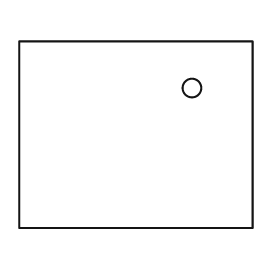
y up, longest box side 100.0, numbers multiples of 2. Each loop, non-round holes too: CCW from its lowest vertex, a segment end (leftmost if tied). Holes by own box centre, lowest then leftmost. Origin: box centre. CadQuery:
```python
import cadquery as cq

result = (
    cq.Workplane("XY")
    .moveTo(-50.0, -40.0)
    .lineTo(50.0, -40.0)
    .lineTo(50.0, 40.0)
    .lineTo(-50.0, 40.0)
    .close()
    .moveTo(24.0, 20.0)
    .circle(4.0)
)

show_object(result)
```